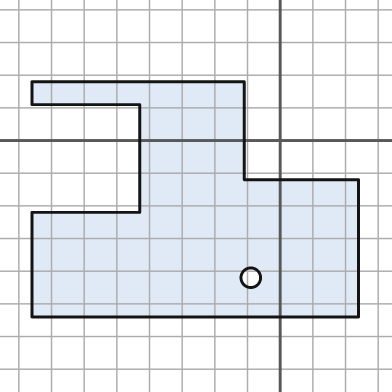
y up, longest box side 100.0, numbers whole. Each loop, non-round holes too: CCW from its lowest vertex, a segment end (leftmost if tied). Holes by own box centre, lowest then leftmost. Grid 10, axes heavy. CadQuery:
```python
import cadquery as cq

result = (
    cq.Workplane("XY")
    .moveTo(-76.0, -54.0)
    .lineTo(24.0, -54.0)
    .lineTo(24.0, -12.0)
    .lineTo(-11.0, -12.0)
    .lineTo(-11.0, 18.0)
    .lineTo(-76.0, 18.0)
    .lineTo(-76.0, 11.0)
    .lineTo(-43.0, 11.0)
    .lineTo(-43.0, -22.0)
    .lineTo(-76.0, -22.0)
    .close()
    .moveTo(-9.0, -42.0)
    .circle(3.0)
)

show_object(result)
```